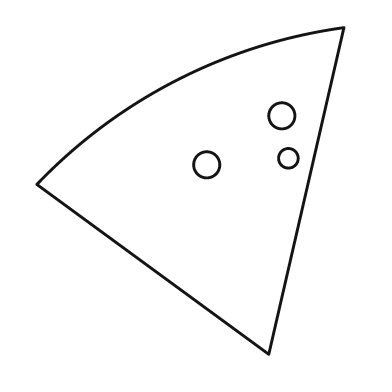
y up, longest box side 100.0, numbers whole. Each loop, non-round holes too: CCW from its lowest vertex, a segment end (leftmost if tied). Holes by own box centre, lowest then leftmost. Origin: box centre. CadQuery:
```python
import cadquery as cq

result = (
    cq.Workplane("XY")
    .moveTo(24.0, -50.0)
    .lineTo(47.0, 50.0)
    .threePointArc((-4.0, 34.0), (-47.0, 2.0))
    .close()
    .moveTo(5.0, 8.0)
    .circle(4.0)
    .moveTo(30.0, 10.0)
    .circle(3.0)
    .moveTo(28.0, 23.0)
    .circle(4.0)
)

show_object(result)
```